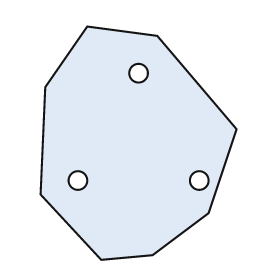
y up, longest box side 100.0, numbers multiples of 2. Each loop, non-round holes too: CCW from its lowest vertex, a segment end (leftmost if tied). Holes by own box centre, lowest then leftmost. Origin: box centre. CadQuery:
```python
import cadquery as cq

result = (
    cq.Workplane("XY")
    .moveTo(-16.0, -50.0)
    .lineTo(6.0, -48.0)
    .lineTo(30.0, -30.0)
    .lineTo(42.0, 6.0)
    .lineTo(8.0, 46.0)
    .lineTo(-22.0, 50.0)
    .lineTo(-40.0, 24.0)
    .lineTo(-42.0, -22.0)
    .close()
    .moveTo(-26.0, -16.0)
    .circle(4.0)
    .moveTo(26.0, -16.0)
    .circle(4.0)
    .moveTo(0.0, 30.0)
    .circle(4.0)
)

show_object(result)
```